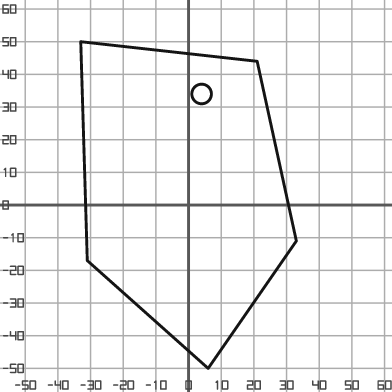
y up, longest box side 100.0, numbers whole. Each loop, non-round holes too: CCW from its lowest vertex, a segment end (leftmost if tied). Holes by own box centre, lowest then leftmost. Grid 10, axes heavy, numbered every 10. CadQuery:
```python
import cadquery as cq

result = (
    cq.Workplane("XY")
    .moveTo(6.0, -50.0)
    .lineTo(33.0, -11.0)
    .lineTo(21.0, 44.0)
    .lineTo(-33.0, 50.0)
    .lineTo(-31.0, -17.0)
    .close()
    .moveTo(4.0, 34.0)
    .circle(3.0)
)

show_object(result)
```